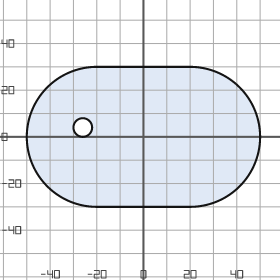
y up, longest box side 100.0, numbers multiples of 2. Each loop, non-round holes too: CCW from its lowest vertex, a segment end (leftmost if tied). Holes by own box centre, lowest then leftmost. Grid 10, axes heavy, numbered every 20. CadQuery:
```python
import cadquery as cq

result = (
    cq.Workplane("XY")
    .moveTo(-20.0, -30.0)
    .lineTo(20.0, -30.0)
    .threePointArc((50.0, 0.0), (20.0, 30.0))
    .lineTo(-20.0, 30.0)
    .threePointArc((-50.0, 0.0), (-20.0, -30.0))
    .close()
    .moveTo(-26.0, 4.0)
    .circle(4.0)
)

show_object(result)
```